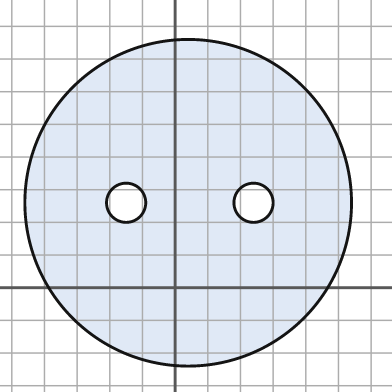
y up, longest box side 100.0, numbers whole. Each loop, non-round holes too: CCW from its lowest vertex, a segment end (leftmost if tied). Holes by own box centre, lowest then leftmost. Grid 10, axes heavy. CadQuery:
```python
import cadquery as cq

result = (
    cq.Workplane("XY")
    .moveTo(4.0, 26.0)
    .circle(50.0)
    .moveTo(-15.0, 26.0)
    .circle(6.0)
    .moveTo(24.0, 26.0)
    .circle(6.0)
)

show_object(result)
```